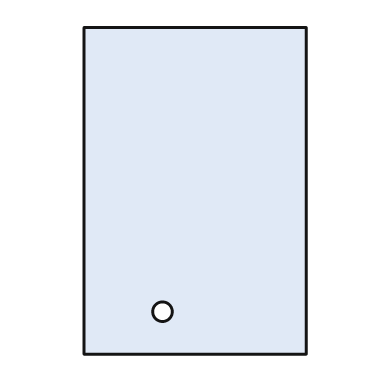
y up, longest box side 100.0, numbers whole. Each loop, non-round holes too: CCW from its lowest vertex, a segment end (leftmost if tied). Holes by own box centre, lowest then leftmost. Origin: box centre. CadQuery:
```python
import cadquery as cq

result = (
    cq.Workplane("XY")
    .moveTo(-34.0, -50.0)
    .lineTo(34.0, -50.0)
    .lineTo(34.0, 50.0)
    .lineTo(-34.0, 50.0)
    .close()
    .moveTo(-10.0, -37.0)
    .circle(3.0)
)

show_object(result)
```